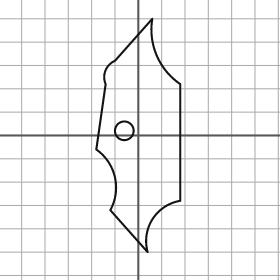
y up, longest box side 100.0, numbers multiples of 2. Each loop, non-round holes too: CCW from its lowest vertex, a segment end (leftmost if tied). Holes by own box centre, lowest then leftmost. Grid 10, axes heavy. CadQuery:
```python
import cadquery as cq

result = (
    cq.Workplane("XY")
    .moveTo(4.0, -50.0)
    .threePointArc((6.0, -36.0), (18.0, -28.0))
    .lineTo(18.0, 22.0)
    .threePointArc((8.0, 34.0), (6.0, 50.0))
    .lineTo(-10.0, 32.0)
    .threePointArc((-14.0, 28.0), (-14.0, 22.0))
    .lineTo(-18.0, -6.0)
    .threePointArc((-10.0, -18.0), (-12.0, -32.0))
    .close()
    .moveTo(-6.0, 2.0)
    .circle(4.0)
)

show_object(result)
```